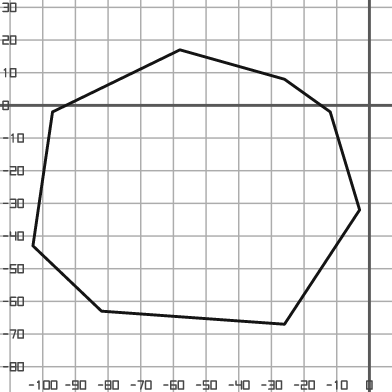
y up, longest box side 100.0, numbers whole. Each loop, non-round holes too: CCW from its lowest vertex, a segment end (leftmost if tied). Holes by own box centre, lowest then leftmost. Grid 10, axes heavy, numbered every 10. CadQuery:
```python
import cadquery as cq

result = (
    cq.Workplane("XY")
    .moveTo(-26.0, -67.0)
    .lineTo(-3.0, -32.0)
    .lineTo(-12.0, -2.0)
    .lineTo(-26.0, 8.0)
    .lineTo(-58.0, 17.0)
    .lineTo(-97.0, -2.0)
    .lineTo(-103.0, -43.0)
    .lineTo(-82.0, -63.0)
    .close()
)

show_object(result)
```